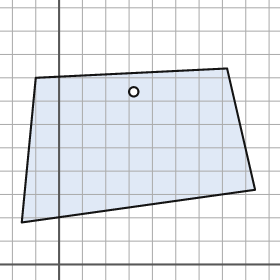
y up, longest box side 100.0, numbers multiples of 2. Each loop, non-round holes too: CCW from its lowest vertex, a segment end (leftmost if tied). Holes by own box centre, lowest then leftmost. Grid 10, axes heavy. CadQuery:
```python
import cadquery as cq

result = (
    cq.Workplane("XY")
    .moveTo(-16.0, 18.0)
    .lineTo(84.0, 32.0)
    .lineTo(72.0, 84.0)
    .lineTo(-10.0, 80.0)
    .close()
    .moveTo(32.0, 74.0)
    .circle(2.0)
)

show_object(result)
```